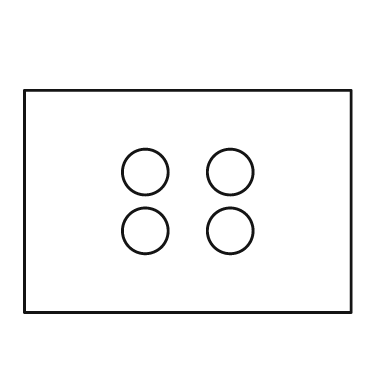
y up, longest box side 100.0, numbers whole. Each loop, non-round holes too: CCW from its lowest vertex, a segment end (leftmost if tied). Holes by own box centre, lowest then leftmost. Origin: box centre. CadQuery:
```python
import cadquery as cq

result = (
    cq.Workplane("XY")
    .moveTo(-50.0, -34.0)
    .lineTo(50.0, -34.0)
    .lineTo(50.0, 34.0)
    .lineTo(-50.0, 34.0)
    .close()
    .moveTo(-13.0, -9.0)
    .circle(7.0)
    .moveTo(13.0, -9.0)
    .circle(7.0)
    .moveTo(-13.0, 9.0)
    .circle(7.0)
    .moveTo(13.0, 9.0)
    .circle(7.0)
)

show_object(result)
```